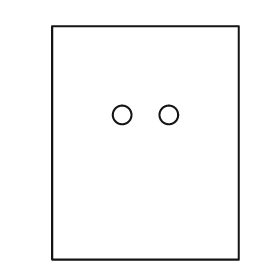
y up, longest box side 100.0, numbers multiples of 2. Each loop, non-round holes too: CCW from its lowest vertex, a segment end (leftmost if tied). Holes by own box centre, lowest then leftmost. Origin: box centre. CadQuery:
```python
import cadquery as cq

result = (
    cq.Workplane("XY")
    .moveTo(-40.0, -50.0)
    .lineTo(40.0, -50.0)
    .lineTo(40.0, 50.0)
    .lineTo(-40.0, 50.0)
    .close()
    .moveTo(-10.0, 12.0)
    .circle(4.0)
    .moveTo(10.0, 12.0)
    .circle(4.0)
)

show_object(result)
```